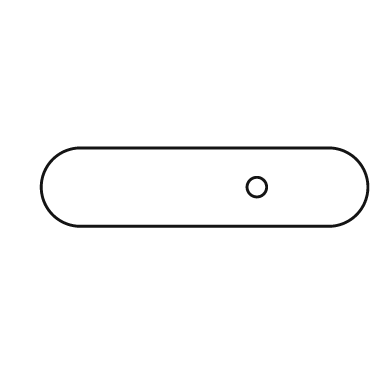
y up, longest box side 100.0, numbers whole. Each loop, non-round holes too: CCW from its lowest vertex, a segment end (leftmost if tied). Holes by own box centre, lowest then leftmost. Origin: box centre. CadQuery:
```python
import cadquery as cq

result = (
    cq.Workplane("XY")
    .moveTo(-38.0, -12.0)
    .lineTo(38.0, -12.0)
    .threePointArc((50.0, 0.0), (38.0, 12.0))
    .lineTo(-38.0, 12.0)
    .threePointArc((-50.0, 0.0), (-38.0, -12.0))
    .close()
    .moveTo(16.0, 0.0)
    .circle(3.0)
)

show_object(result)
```